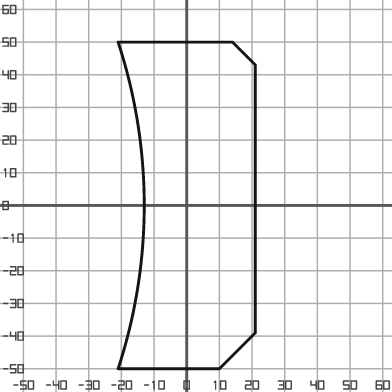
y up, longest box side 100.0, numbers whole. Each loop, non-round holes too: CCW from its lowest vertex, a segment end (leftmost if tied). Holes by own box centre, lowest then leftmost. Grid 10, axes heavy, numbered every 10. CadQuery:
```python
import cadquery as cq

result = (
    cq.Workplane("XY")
    .moveTo(-21.0, -50.0)
    .lineTo(10.0, -50.0)
    .lineTo(21.0, -39.0)
    .lineTo(21.0, 43.0)
    .lineTo(14.0, 50.0)
    .lineTo(-21.0, 50.0)
    .threePointArc((-13.0, 0.0), (-21.0, -50.0))
    .close()
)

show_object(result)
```